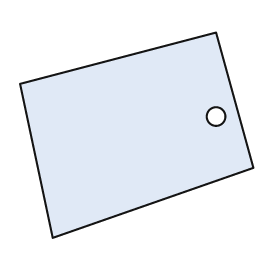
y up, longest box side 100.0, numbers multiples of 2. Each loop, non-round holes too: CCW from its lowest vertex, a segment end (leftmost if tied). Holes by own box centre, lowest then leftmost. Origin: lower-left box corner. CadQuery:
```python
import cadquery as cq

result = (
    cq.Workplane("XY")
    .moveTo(14.0, 0.0)
    .lineTo(100.0, 30.0)
    .lineTo(84.0, 88.0)
    .lineTo(0.0, 66.0)
    .close()
    .moveTo(84.0, 52.0)
    .circle(4.0)
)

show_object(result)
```